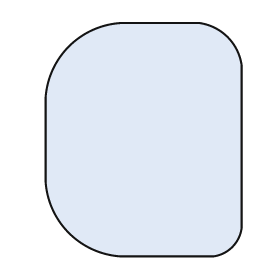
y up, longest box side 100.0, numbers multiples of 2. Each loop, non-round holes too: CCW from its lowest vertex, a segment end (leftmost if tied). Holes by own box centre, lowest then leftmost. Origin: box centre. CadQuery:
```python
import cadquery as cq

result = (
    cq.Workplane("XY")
    .moveTo(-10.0, -50.0)
    .lineTo(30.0, -50.0)
    .threePointArc((38.0, -46.0), (42.0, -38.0))
    .lineTo(42.0, 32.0)
    .threePointArc((36.0, 44.0), (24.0, 50.0))
    .lineTo(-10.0, 50.0)
    .threePointArc((-32.0, 40.0), (-42.0, 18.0))
    .lineTo(-42.0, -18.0)
    .threePointArc((-32.0, -40.0), (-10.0, -50.0))
    .close()
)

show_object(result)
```